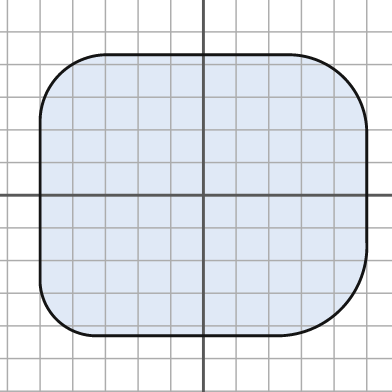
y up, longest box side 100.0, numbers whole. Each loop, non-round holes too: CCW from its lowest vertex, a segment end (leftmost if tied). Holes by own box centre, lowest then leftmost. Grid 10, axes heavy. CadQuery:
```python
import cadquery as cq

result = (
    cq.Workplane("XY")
    .moveTo(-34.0, -43.0)
    .lineTo(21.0, -43.0)
    .threePointArc((42.0, -35.0), (50.0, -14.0))
    .lineTo(50.0, 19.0)
    .threePointArc((43.0, 36.0), (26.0, 43.0))
    .lineTo(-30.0, 43.0)
    .threePointArc((-44.0, 37.0), (-50.0, 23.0))
    .lineTo(-50.0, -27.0)
    .threePointArc((-45.0, -38.0), (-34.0, -43.0))
    .close()
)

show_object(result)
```